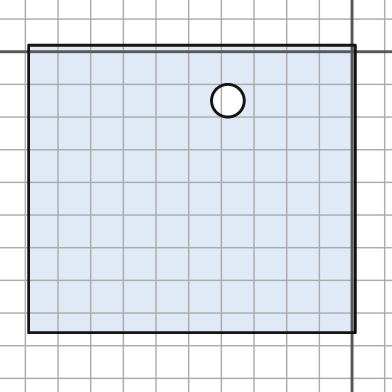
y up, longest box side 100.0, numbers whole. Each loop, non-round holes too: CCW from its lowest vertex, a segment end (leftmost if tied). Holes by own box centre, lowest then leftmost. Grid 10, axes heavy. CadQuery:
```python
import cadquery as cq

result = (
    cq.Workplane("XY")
    .moveTo(-99.0, -86.0)
    .lineTo(1.0, -86.0)
    .lineTo(1.0, 2.0)
    .lineTo(-99.0, 2.0)
    .close()
    .moveTo(-38.0, -15.0)
    .circle(5.0)
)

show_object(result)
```